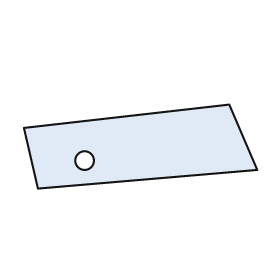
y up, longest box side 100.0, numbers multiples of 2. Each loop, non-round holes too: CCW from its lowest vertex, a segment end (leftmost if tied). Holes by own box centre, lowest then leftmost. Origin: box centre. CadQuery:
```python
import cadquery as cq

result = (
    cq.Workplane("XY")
    .moveTo(-44.0, -18.0)
    .lineTo(50.0, -10.0)
    .lineTo(38.0, 18.0)
    .lineTo(-50.0, 8.0)
    .close()
    .moveTo(-24.0, -6.0)
    .circle(4.0)
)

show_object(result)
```